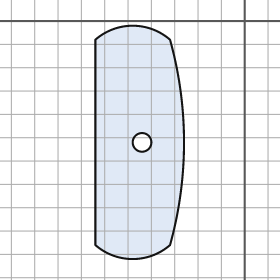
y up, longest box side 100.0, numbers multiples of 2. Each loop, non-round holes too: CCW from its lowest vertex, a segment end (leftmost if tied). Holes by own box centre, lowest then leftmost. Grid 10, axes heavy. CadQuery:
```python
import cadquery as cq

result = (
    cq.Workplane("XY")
    .moveTo(-64.0, -96.0)
    .threePointArc((-48.0, -102.0), (-32.0, -96.0))
    .threePointArc((-26.0, -52.0), (-32.0, -8.0))
    .threePointArc((-48.0, -2.0), (-64.0, -8.0))
    .close()
    .moveTo(-44.0, -52.0)
    .circle(4.0)
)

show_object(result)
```